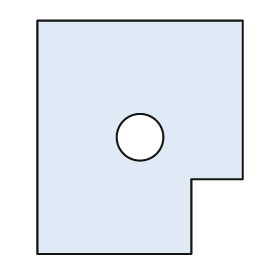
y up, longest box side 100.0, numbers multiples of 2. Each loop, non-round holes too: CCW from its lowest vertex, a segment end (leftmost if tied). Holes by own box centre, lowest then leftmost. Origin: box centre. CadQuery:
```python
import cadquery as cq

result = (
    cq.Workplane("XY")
    .moveTo(-44.0, -50.0)
    .lineTo(22.0, -50.0)
    .lineTo(22.0, -18.0)
    .lineTo(44.0, -18.0)
    .lineTo(44.0, 50.0)
    .lineTo(-44.0, 50.0)
    .close()
    .moveTo(0.0, 0.0)
    .circle(10.0)
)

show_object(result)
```